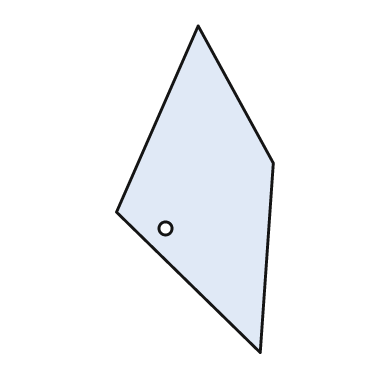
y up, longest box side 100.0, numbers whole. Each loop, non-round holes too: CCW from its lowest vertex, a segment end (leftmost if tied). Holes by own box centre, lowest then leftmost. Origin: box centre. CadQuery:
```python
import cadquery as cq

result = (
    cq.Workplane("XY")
    .moveTo(20.0, -50.0)
    .lineTo(24.0, 8.0)
    .lineTo(1.0, 50.0)
    .lineTo(-24.0, -7.0)
    .close()
    .moveTo(-9.0, -12.0)
    .circle(2.0)
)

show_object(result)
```